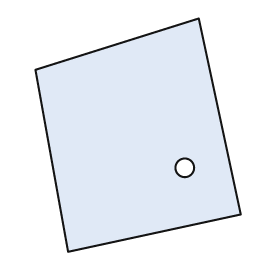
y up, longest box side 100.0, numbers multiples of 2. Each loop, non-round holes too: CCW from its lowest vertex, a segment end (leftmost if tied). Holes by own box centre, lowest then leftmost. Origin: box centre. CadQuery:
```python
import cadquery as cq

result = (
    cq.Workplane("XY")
    .moveTo(-30.0, -50.0)
    .lineTo(44.0, -34.0)
    .lineTo(26.0, 50.0)
    .lineTo(-44.0, 28.0)
    .close()
    .moveTo(20.0, -14.0)
    .circle(4.0)
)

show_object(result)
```